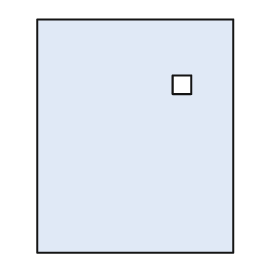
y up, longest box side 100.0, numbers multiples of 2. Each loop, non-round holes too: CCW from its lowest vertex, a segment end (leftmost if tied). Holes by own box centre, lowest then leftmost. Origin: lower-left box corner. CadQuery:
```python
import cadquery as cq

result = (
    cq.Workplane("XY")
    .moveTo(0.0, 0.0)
    .lineTo(84.0, 0.0)
    .lineTo(84.0, 100.0)
    .lineTo(0.0, 100.0)
    .close()
    .moveTo(58.0, 68.0)
    .lineTo(66.0, 68.0)
    .lineTo(66.0, 76.0)
    .lineTo(58.0, 76.0)
    .close()
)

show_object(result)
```